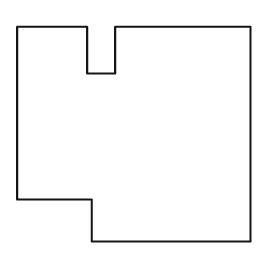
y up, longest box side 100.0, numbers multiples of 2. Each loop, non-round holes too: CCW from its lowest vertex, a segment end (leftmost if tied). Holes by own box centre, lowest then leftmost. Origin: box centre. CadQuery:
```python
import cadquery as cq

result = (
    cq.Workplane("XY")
    .moveTo(-18.0, -46.0)
    .lineTo(50.0, -46.0)
    .lineTo(50.0, 46.0)
    .lineTo(-8.0, 46.0)
    .lineTo(-8.0, 26.0)
    .lineTo(-20.0, 26.0)
    .lineTo(-20.0, 46.0)
    .lineTo(-50.0, 46.0)
    .lineTo(-50.0, -28.0)
    .lineTo(-18.0, -28.0)
    .close()
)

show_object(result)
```